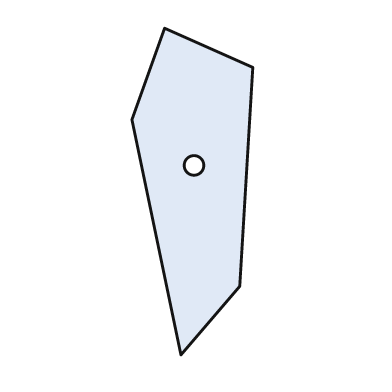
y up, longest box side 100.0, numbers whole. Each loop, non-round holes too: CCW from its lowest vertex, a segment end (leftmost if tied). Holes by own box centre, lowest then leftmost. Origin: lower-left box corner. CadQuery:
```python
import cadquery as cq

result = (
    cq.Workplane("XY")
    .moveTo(15.0, 0.0)
    .lineTo(33.0, 21.0)
    .lineTo(37.0, 88.0)
    .lineTo(10.0, 100.0)
    .lineTo(0.0, 72.0)
    .close()
    .moveTo(19.0, 58.0)
    .circle(3.0)
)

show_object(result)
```